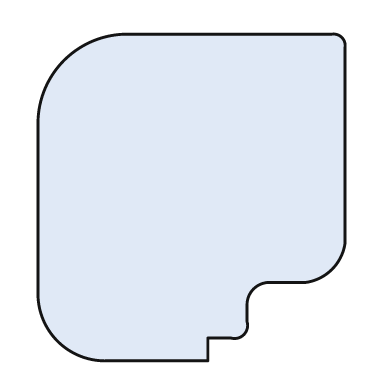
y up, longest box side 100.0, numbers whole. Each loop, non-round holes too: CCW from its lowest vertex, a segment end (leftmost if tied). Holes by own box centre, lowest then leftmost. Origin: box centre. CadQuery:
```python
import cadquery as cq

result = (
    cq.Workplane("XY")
    .moveTo(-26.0, -50.0)
    .lineTo(5.0, -50.0)
    .lineTo(5.0, -43.0)
    .lineTo(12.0, -43.0)
    .threePointArc((16.0, -42.0), (17.0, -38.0))
    .lineTo(17.0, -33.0)
    .threePointArc((19.0, -28.0), (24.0, -26.0))
    .lineTo(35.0, -26.0)
    .threePointArc((43.0, -22.0), (47.0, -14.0))
    .lineTo(47.0, 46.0)
    .threePointArc((46.0, 49.0), (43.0, 50.0))
    .lineTo(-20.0, 50.0)
    .threePointArc((-39.0, 42.0), (-47.0, 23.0))
    .lineTo(-47.0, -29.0)
    .threePointArc((-41.0, -44.0), (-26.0, -50.0))
    .close()
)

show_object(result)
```